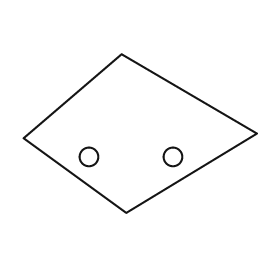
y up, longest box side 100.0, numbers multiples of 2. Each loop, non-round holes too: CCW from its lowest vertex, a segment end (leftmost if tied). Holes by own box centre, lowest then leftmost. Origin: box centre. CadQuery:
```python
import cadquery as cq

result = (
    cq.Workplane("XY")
    .moveTo(-6.0, -34.0)
    .lineTo(50.0, 0.0)
    .lineTo(-8.0, 34.0)
    .lineTo(-50.0, -2.0)
    .close()
    .moveTo(-22.0, -10.0)
    .circle(4.0)
    .moveTo(14.0, -10.0)
    .circle(4.0)
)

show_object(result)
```